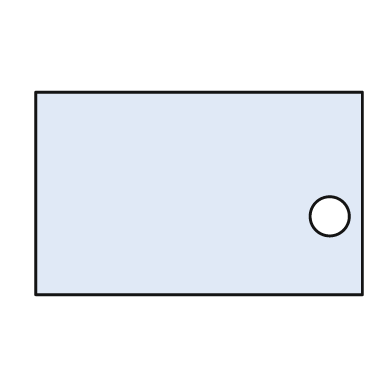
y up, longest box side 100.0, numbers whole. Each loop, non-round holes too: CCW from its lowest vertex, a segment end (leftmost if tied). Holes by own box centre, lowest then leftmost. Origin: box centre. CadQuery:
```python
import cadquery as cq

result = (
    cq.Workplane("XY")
    .moveTo(-50.0, -31.0)
    .lineTo(50.0, -31.0)
    .lineTo(50.0, 31.0)
    .lineTo(-50.0, 31.0)
    .close()
    .moveTo(40.0, -7.0)
    .circle(6.0)
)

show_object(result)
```